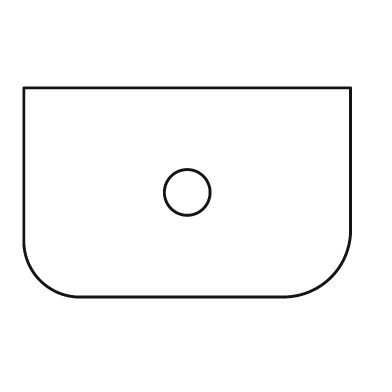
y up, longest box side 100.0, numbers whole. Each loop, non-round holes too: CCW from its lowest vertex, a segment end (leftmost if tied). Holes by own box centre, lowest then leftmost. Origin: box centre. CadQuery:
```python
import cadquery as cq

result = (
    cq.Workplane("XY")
    .moveTo(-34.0, -32.0)
    .lineTo(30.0, -32.0)
    .threePointArc((44.0, -26.0), (50.0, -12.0))
    .lineTo(50.0, 32.0)
    .lineTo(-50.0, 32.0)
    .lineTo(-50.0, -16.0)
    .threePointArc((-45.0, -27.0), (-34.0, -32.0))
    .close()
    .moveTo(0.0, 0.0)
    .circle(7.0)
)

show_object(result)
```